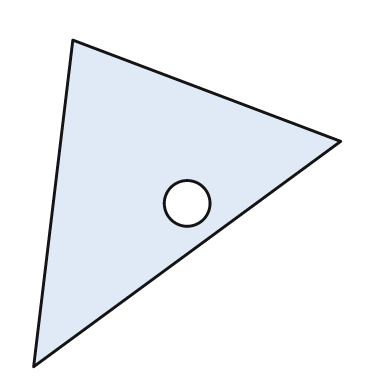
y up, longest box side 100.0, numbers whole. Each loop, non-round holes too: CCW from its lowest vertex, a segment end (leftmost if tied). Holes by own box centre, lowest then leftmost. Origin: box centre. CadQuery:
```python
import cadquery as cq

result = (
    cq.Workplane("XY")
    .moveTo(-47.0, -50.0)
    .lineTo(47.0, 19.0)
    .lineTo(-35.0, 50.0)
    .close()
    .moveTo(0.0, 0.0)
    .circle(7.0)
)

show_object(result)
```